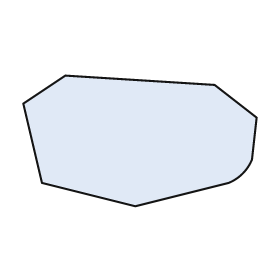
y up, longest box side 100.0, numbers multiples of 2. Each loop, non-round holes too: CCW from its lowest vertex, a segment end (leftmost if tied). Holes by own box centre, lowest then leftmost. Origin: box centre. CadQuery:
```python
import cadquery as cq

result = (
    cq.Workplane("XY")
    .moveTo(-2.0, -28.0)
    .lineTo(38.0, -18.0)
    .threePointArc((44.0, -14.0), (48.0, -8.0))
    .lineTo(50.0, 10.0)
    .lineTo(32.0, 24.0)
    .lineTo(-32.0, 28.0)
    .lineTo(-50.0, 16.0)
    .lineTo(-42.0, -18.0)
    .close()
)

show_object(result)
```